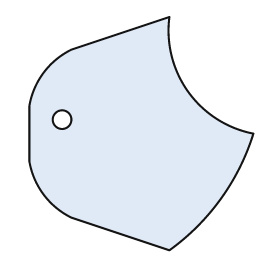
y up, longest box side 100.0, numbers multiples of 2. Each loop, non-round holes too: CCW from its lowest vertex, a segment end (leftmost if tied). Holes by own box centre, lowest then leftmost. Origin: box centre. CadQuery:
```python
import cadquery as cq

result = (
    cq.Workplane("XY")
    .moveTo(12.0, -50.0)
    .threePointArc((34.0, -28.0), (48.0, 0.0))
    .threePointArc((20.0, 18.0), (12.0, 50.0))
    .lineTo(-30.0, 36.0)
    .threePointArc((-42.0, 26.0), (-48.0, 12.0))
    .lineTo(-48.0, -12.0)
    .threePointArc((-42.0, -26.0), (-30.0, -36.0))
    .close()
    .moveTo(-34.0, 6.0)
    .circle(4.0)
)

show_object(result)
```